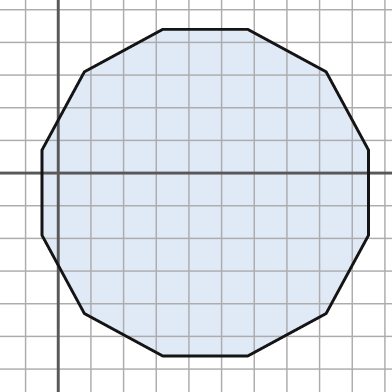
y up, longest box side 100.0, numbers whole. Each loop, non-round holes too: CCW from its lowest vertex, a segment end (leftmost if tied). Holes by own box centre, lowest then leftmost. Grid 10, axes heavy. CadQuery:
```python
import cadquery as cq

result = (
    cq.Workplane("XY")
    .moveTo(32.0, -56.0)
    .lineTo(58.0, -56.0)
    .lineTo(82.0, -43.0)
    .lineTo(95.0, -19.0)
    .lineTo(95.0, 7.0)
    .lineTo(82.0, 31.0)
    .lineTo(58.0, 44.0)
    .lineTo(32.0, 44.0)
    .lineTo(8.0, 31.0)
    .lineTo(-5.0, 7.0)
    .lineTo(-5.0, -19.0)
    .lineTo(8.0, -43.0)
    .close()
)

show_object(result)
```